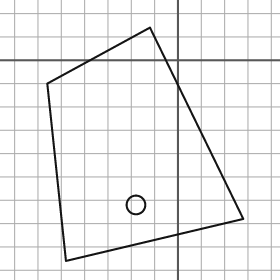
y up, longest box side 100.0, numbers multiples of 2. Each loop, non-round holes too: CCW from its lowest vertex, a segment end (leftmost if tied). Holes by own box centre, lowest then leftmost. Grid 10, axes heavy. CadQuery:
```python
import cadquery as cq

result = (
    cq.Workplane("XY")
    .moveTo(-48.0, -86.0)
    .lineTo(28.0, -68.0)
    .lineTo(-12.0, 14.0)
    .lineTo(-56.0, -10.0)
    .close()
    .moveTo(-18.0, -62.0)
    .circle(4.0)
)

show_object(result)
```